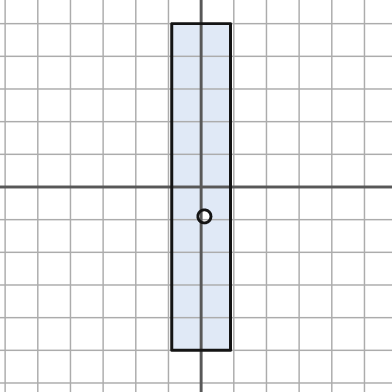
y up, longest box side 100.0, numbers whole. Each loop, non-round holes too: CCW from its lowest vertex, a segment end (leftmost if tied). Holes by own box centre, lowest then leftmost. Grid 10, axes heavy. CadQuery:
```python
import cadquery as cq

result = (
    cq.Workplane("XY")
    .moveTo(-9.0, -50.0)
    .lineTo(9.0, -50.0)
    .lineTo(9.0, 50.0)
    .lineTo(-9.0, 50.0)
    .close()
    .moveTo(1.0, -9.0)
    .circle(2.0)
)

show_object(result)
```